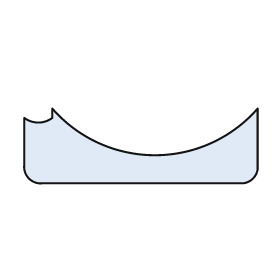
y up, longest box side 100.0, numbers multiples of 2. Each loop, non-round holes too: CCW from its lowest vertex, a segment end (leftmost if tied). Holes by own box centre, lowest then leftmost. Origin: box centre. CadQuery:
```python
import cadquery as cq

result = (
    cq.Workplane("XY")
    .moveTo(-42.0, -16.0)
    .lineTo(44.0, -16.0)
    .threePointArc((48.0, -14.0), (50.0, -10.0))
    .lineTo(50.0, 16.0)
    .threePointArc((6.0, -4.0), (-38.0, 16.0))
    .lineTo(-38.0, 12.0)
    .threePointArc((-44.0, 10.0), (-50.0, 12.0))
    .lineTo(-50.0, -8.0)
    .threePointArc((-48.0, -14.0), (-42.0, -16.0))
    .close()
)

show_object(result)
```